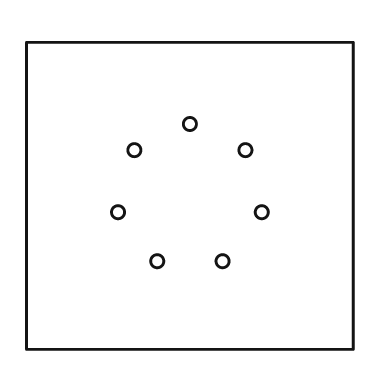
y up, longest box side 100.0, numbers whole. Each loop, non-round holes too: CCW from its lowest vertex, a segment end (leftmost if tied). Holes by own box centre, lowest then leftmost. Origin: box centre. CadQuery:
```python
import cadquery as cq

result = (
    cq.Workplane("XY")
    .moveTo(-50.0, -47.0)
    .lineTo(50.0, -47.0)
    .lineTo(50.0, 47.0)
    .lineTo(-50.0, 47.0)
    .close()
    .moveTo(-10.0, -20.0)
    .circle(2.0)
    .moveTo(10.0, -20.0)
    .circle(2.0)
    .moveTo(-22.0, -5.0)
    .circle(2.0)
    .moveTo(22.0, -5.0)
    .circle(2.0)
    .moveTo(-17.0, 14.0)
    .circle(2.0)
    .moveTo(17.0, 14.0)
    .circle(2.0)
    .moveTo(0.0, 22.0)
    .circle(2.0)
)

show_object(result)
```